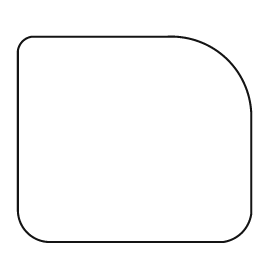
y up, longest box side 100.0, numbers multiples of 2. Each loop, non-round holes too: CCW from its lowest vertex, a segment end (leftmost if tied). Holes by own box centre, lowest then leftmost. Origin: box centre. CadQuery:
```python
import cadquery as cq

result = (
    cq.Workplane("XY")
    .moveTo(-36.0, -44.0)
    .lineTo(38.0, -44.0)
    .threePointArc((46.0, -40.0), (50.0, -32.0))
    .lineTo(50.0, 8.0)
    .threePointArc((40.0, 34.0), (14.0, 44.0))
    .lineTo(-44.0, 44.0)
    .threePointArc((-48.0, 42.0), (-50.0, 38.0))
    .lineTo(-50.0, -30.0)
    .threePointArc((-46.0, -40.0), (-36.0, -44.0))
    .close()
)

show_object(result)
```